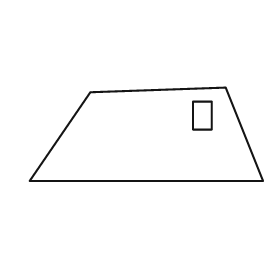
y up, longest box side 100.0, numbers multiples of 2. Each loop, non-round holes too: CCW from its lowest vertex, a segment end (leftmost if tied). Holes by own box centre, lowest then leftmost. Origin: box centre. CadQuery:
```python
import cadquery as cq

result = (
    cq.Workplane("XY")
    .moveTo(-50.0, -20.0)
    .lineTo(50.0, -20.0)
    .lineTo(34.0, 20.0)
    .lineTo(-24.0, 18.0)
    .close()
    .moveTo(20.0, 2.0)
    .lineTo(28.0, 2.0)
    .lineTo(28.0, 14.0)
    .lineTo(20.0, 14.0)
    .close()
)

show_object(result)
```